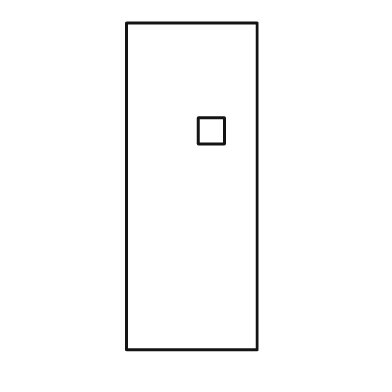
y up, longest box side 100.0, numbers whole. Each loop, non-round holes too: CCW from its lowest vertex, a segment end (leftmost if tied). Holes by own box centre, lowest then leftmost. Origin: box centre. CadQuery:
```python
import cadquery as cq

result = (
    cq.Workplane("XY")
    .moveTo(-20.0, -50.0)
    .lineTo(20.0, -50.0)
    .lineTo(20.0, 50.0)
    .lineTo(-20.0, 50.0)
    .close()
    .moveTo(2.0, 13.0)
    .lineTo(10.0, 13.0)
    .lineTo(10.0, 21.0)
    .lineTo(2.0, 21.0)
    .close()
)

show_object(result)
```